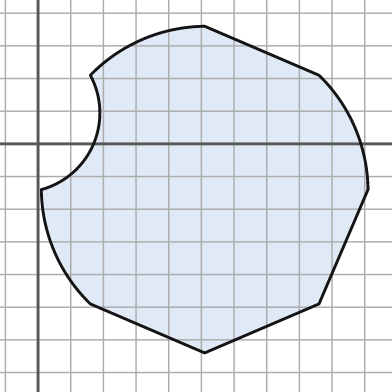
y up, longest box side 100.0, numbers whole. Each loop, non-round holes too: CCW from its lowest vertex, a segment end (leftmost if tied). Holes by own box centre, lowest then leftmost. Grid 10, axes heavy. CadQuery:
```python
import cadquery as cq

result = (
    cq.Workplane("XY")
    .moveTo(51.0, -64.0)
    .lineTo(86.0, -49.0)
    .lineTo(101.0, -14.0)
    .threePointArc((97.0, 5.0), (86.0, 21.0))
    .lineTo(51.0, 36.0)
    .threePointArc((32.0, 32.0), (16.0, 21.0))
    .threePointArc((17.0, 0.0), (1.0, -14.0))
    .threePointArc((5.0, -33.0), (16.0, -49.0))
    .close()
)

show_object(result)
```